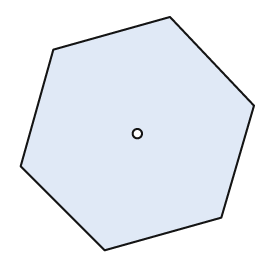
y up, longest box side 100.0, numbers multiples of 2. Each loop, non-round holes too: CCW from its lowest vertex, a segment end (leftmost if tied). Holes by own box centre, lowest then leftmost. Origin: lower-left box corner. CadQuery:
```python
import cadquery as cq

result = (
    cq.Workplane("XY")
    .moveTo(36.0, 0.0)
    .lineTo(86.0, 14.0)
    .lineTo(100.0, 62.0)
    .lineTo(64.0, 100.0)
    .lineTo(14.0, 86.0)
    .lineTo(0.0, 36.0)
    .close()
    .moveTo(50.0, 50.0)
    .circle(2.0)
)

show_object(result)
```